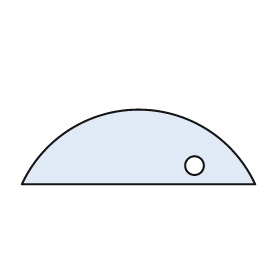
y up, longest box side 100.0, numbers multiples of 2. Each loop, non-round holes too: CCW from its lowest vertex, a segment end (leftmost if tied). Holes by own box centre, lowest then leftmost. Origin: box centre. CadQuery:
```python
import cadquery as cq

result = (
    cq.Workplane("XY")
    .moveTo(-50.0, -16.0)
    .lineTo(50.0, -16.0)
    .threePointArc((0.0, 16.0), (-50.0, -16.0))
    .close()
    .moveTo(24.0, -8.0)
    .circle(4.0)
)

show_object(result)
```